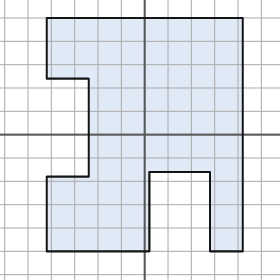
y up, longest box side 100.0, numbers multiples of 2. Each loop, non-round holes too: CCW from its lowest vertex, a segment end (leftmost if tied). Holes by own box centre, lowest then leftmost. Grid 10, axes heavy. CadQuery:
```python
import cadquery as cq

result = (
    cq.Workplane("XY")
    .moveTo(-42.0, -50.0)
    .lineTo(2.0, -50.0)
    .lineTo(2.0, -16.0)
    .lineTo(28.0, -16.0)
    .lineTo(28.0, -50.0)
    .lineTo(42.0, -50.0)
    .lineTo(42.0, 50.0)
    .lineTo(-42.0, 50.0)
    .lineTo(-42.0, 24.0)
    .lineTo(-24.0, 24.0)
    .lineTo(-24.0, -18.0)
    .lineTo(-42.0, -18.0)
    .close()
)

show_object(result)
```